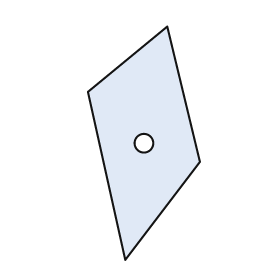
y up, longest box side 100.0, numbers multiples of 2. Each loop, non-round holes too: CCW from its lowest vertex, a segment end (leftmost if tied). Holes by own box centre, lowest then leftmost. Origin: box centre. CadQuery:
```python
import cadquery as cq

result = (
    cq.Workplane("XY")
    .moveTo(-8.0, -50.0)
    .lineTo(24.0, -8.0)
    .lineTo(10.0, 50.0)
    .lineTo(-24.0, 22.0)
    .close()
    .moveTo(0.0, 0.0)
    .circle(4.0)
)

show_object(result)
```